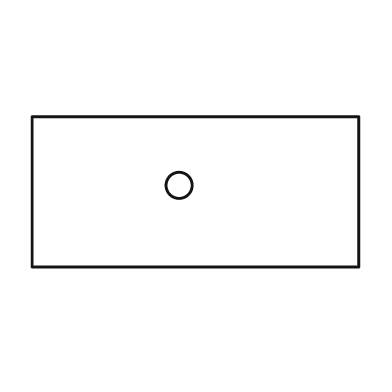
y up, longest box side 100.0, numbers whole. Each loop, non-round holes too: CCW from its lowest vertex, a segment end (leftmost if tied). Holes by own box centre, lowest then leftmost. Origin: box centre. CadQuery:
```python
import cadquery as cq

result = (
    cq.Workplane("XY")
    .moveTo(-50.0, -23.0)
    .lineTo(50.0, -23.0)
    .lineTo(50.0, 23.0)
    .lineTo(-50.0, 23.0)
    .close()
    .moveTo(-5.0, 2.0)
    .circle(4.0)
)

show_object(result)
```